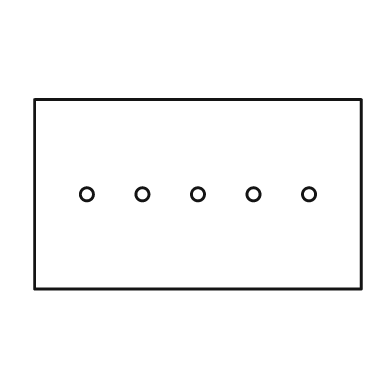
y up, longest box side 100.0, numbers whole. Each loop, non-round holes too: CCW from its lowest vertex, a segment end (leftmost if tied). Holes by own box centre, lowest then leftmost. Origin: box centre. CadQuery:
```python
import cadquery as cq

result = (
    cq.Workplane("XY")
    .moveTo(-50.0, -29.0)
    .lineTo(50.0, -29.0)
    .lineTo(50.0, 29.0)
    .lineTo(-50.0, 29.0)
    .close()
    .moveTo(-34.0, 0.0)
    .circle(2.0)
    .moveTo(-17.0, 0.0)
    .circle(2.0)
    .moveTo(0.0, 0.0)
    .circle(2.0)
    .moveTo(17.0, 0.0)
    .circle(2.0)
    .moveTo(34.0, 0.0)
    .circle(2.0)
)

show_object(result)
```